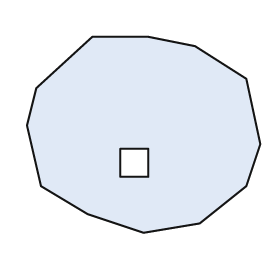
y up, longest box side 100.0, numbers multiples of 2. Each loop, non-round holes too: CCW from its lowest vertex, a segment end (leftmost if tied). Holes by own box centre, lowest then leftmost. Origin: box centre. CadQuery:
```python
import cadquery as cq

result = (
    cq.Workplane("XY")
    .moveTo(0.0, -42.0)
    .lineTo(24.0, -38.0)
    .lineTo(44.0, -22.0)
    .lineTo(50.0, -4.0)
    .lineTo(44.0, 24.0)
    .lineTo(22.0, 38.0)
    .lineTo(2.0, 42.0)
    .lineTo(-22.0, 42.0)
    .lineTo(-46.0, 20.0)
    .lineTo(-50.0, 4.0)
    .lineTo(-44.0, -22.0)
    .lineTo(-24.0, -34.0)
    .close()
    .moveTo(-10.0, -18.0)
    .lineTo(2.0, -18.0)
    .lineTo(2.0, -6.0)
    .lineTo(-10.0, -6.0)
    .close()
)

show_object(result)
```